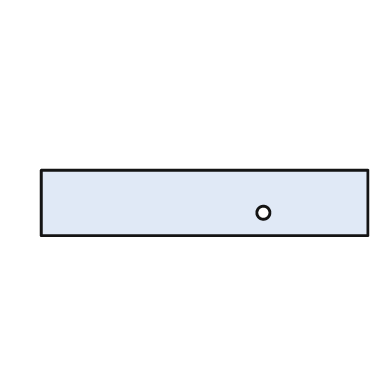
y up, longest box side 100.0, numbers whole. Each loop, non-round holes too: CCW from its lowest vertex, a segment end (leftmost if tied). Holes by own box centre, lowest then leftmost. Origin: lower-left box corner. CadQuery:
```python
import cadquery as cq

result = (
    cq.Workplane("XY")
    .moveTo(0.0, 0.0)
    .lineTo(100.0, 0.0)
    .lineTo(100.0, 20.0)
    .lineTo(0.0, 20.0)
    .close()
    .moveTo(68.0, 7.0)
    .circle(2.0)
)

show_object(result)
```